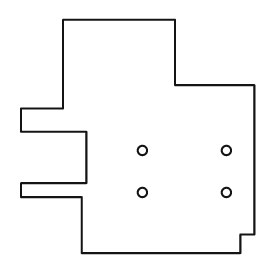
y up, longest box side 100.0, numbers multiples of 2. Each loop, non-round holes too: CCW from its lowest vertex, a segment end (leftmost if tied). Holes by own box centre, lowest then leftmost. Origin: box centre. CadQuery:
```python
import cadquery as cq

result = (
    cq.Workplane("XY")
    .moveTo(-24.0, -50.0)
    .lineTo(44.0, -50.0)
    .lineTo(44.0, -42.0)
    .lineTo(50.0, -42.0)
    .lineTo(50.0, 22.0)
    .lineTo(16.0, 22.0)
    .lineTo(16.0, 50.0)
    .lineTo(-32.0, 50.0)
    .lineTo(-32.0, 12.0)
    .lineTo(-50.0, 12.0)
    .lineTo(-50.0, 2.0)
    .lineTo(-22.0, 2.0)
    .lineTo(-22.0, -20.0)
    .lineTo(-50.0, -20.0)
    .lineTo(-50.0, -26.0)
    .lineTo(-24.0, -26.0)
    .close()
    .moveTo(2.0, -24.0)
    .circle(2.0)
    .moveTo(38.0, -24.0)
    .circle(2.0)
    .moveTo(2.0, -6.0)
    .circle(2.0)
    .moveTo(38.0, -6.0)
    .circle(2.0)
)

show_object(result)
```